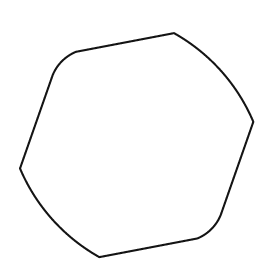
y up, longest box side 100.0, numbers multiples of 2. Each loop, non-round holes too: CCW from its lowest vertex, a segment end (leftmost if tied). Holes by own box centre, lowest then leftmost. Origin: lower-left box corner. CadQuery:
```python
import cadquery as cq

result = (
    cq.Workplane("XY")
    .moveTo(34.0, 0.0)
    .lineTo(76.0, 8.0)
    .threePointArc((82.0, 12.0), (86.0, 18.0))
    .lineTo(100.0, 58.0)
    .threePointArc((86.0, 80.0), (66.0, 96.0))
    .lineTo(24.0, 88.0)
    .threePointArc((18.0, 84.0), (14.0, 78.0))
    .lineTo(0.0, 38.0)
    .threePointArc((14.0, 16.0), (34.0, 0.0))
    .close()
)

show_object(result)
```